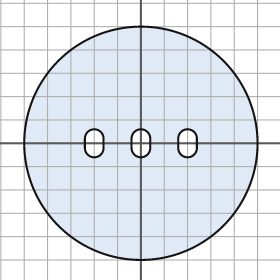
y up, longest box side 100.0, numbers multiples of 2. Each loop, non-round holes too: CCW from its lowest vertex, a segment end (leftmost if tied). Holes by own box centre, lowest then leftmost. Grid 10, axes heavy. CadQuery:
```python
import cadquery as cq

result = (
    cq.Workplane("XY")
    .moveTo(0.0, 0.0)
    .circle(50.0)
    .moveTo(-24.0, -2.0)
    .threePointArc((-20.0, -6.0), (-16.0, -2.0))
    .lineTo(-16.0, 2.0)
    .threePointArc((-20.0, 6.0), (-24.0, 2.0))
    .close()
    .moveTo(-4.0, -2.0)
    .threePointArc((0.0, -6.0), (4.0, -2.0))
    .lineTo(4.0, 2.0)
    .threePointArc((0.0, 6.0), (-4.0, 2.0))
    .close()
    .moveTo(16.0, -2.0)
    .threePointArc((20.0, -6.0), (24.0, -2.0))
    .lineTo(24.0, 2.0)
    .threePointArc((20.0, 6.0), (16.0, 2.0))
    .close()
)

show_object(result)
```